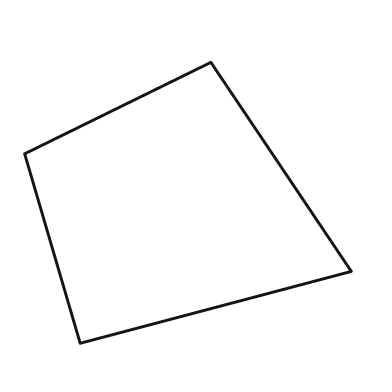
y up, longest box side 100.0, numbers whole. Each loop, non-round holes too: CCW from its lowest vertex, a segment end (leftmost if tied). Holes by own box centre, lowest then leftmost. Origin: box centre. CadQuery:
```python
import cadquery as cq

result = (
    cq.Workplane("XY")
    .moveTo(-33.0, -43.0)
    .lineTo(50.0, -21.0)
    .lineTo(7.0, 43.0)
    .lineTo(-50.0, 15.0)
    .close()
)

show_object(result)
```